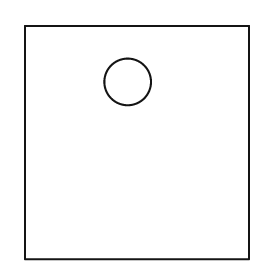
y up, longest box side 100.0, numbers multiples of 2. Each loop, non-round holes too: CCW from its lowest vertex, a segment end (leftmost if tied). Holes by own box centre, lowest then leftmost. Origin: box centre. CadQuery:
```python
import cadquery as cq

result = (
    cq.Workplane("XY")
    .moveTo(-48.0, -50.0)
    .lineTo(48.0, -50.0)
    .lineTo(48.0, 50.0)
    .lineTo(-48.0, 50.0)
    .close()
    .moveTo(-4.0, 26.0)
    .circle(10.0)
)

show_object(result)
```